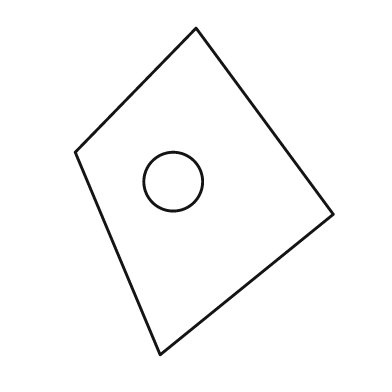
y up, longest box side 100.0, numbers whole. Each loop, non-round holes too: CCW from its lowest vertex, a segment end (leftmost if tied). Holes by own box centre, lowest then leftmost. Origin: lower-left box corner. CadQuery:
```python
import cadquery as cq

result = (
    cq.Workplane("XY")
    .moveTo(26.0, 0.0)
    .lineTo(79.0, 43.0)
    .lineTo(37.0, 100.0)
    .lineTo(0.0, 62.0)
    .close()
    .moveTo(30.0, 53.0)
    .circle(9.0)
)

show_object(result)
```